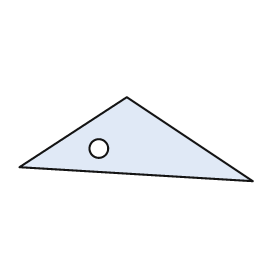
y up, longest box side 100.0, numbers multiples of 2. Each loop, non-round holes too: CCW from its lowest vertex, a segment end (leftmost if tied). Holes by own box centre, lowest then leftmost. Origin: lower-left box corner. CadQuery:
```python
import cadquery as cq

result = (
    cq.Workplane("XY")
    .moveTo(100.0, 0.0)
    .lineTo(46.0, 36.0)
    .lineTo(0.0, 6.0)
    .close()
    .moveTo(34.0, 14.0)
    .circle(4.0)
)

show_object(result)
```